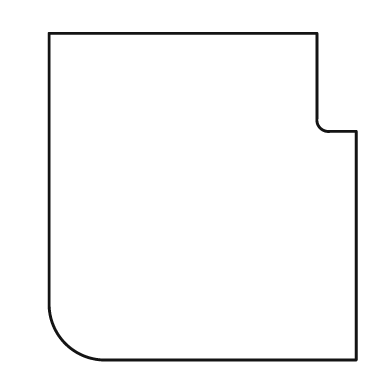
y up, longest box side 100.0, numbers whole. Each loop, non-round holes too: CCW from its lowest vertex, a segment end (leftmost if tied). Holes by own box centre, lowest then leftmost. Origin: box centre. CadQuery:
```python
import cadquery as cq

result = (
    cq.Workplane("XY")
    .moveTo(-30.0, -50.0)
    .lineTo(47.0, -50.0)
    .lineTo(47.0, 20.0)
    .lineTo(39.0, 20.0)
    .threePointArc((36.0, 21.0), (35.0, 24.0))
    .lineTo(35.0, 50.0)
    .lineTo(-47.0, 50.0)
    .lineTo(-47.0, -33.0)
    .threePointArc((-42.0, -45.0), (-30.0, -50.0))
    .close()
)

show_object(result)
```